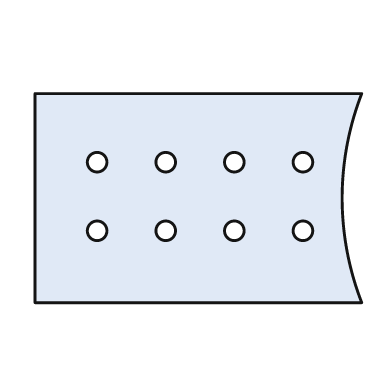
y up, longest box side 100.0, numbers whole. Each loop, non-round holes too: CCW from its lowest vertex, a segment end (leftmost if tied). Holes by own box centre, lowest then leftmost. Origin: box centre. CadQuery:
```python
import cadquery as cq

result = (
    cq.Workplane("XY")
    .moveTo(-50.0, -32.0)
    .lineTo(50.0, -32.0)
    .threePointArc((44.0, 0.0), (50.0, 32.0))
    .lineTo(-50.0, 32.0)
    .close()
    .moveTo(-31.0, -10.0)
    .circle(3.0)
    .moveTo(-10.0, -10.0)
    .circle(3.0)
    .moveTo(11.0, -10.0)
    .circle(3.0)
    .moveTo(32.0, -10.0)
    .circle(3.0)
    .moveTo(-31.0, 11.0)
    .circle(3.0)
    .moveTo(-10.0, 11.0)
    .circle(3.0)
    .moveTo(11.0, 11.0)
    .circle(3.0)
    .moveTo(32.0, 11.0)
    .circle(3.0)
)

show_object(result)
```